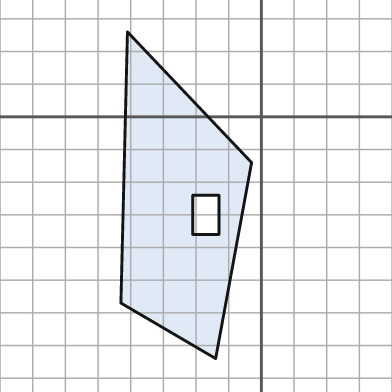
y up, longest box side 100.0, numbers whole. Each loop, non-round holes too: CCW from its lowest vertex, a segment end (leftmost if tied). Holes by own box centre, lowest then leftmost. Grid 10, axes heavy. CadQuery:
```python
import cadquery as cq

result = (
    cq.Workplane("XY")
    .moveTo(-14.0, -74.0)
    .lineTo(-3.0, -14.0)
    .lineTo(-41.0, 26.0)
    .lineTo(-43.0, -57.0)
    .close()
    .moveTo(-21.0, -36.0)
    .lineTo(-13.0, -36.0)
    .lineTo(-13.0, -24.0)
    .lineTo(-21.0, -24.0)
    .close()
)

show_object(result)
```